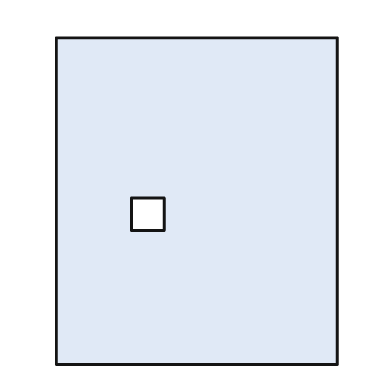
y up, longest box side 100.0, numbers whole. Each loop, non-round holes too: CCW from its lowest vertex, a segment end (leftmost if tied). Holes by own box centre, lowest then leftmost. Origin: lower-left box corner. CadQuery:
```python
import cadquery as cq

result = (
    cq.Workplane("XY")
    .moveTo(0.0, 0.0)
    .lineTo(86.0, 0.0)
    .lineTo(86.0, 100.0)
    .lineTo(0.0, 100.0)
    .close()
    .moveTo(23.0, 41.0)
    .lineTo(33.0, 41.0)
    .lineTo(33.0, 51.0)
    .lineTo(23.0, 51.0)
    .close()
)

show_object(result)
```